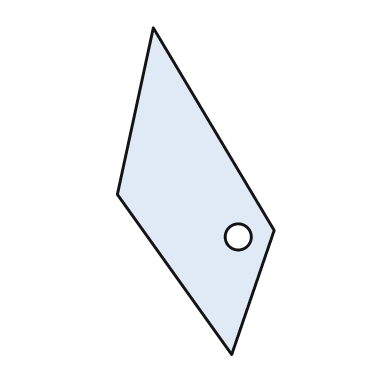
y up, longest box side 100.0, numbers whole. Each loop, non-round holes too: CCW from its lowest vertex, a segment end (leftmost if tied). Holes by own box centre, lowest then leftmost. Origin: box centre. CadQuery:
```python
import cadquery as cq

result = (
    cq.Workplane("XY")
    .moveTo(11.0, -50.0)
    .lineTo(24.0, -12.0)
    .lineTo(-13.0, 50.0)
    .lineTo(-24.0, -1.0)
    .close()
    .moveTo(13.0, -14.0)
    .circle(4.0)
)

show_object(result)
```